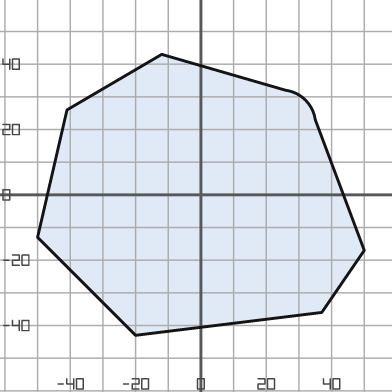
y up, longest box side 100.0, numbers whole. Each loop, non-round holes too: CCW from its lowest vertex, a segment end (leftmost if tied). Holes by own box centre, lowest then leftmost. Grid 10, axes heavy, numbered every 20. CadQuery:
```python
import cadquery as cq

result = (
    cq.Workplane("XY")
    .moveTo(-20.0, -43.0)
    .lineTo(37.0, -36.0)
    .lineTo(50.0, -17.0)
    .lineTo(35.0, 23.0)
    .threePointArc((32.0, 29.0), (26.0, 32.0))
    .lineTo(-12.0, 43.0)
    .lineTo(-41.0, 26.0)
    .lineTo(-50.0, -13.0)
    .close()
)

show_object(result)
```